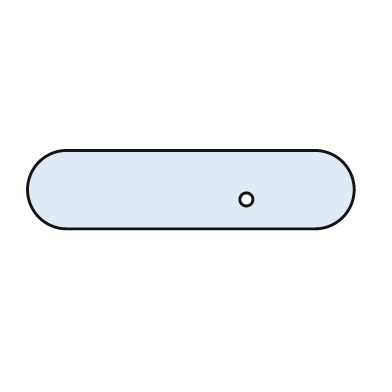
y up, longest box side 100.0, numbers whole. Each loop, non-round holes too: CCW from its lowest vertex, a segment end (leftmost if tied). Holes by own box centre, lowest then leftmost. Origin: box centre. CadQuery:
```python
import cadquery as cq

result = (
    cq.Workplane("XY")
    .moveTo(-38.0, -12.0)
    .lineTo(38.0, -12.0)
    .threePointArc((50.0, 0.0), (38.0, 12.0))
    .lineTo(-38.0, 12.0)
    .threePointArc((-50.0, 0.0), (-38.0, -12.0))
    .close()
    .moveTo(17.0, -3.0)
    .circle(2.0)
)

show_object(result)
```